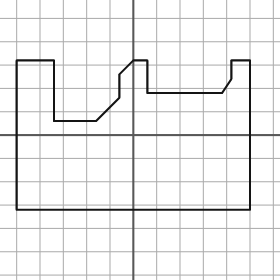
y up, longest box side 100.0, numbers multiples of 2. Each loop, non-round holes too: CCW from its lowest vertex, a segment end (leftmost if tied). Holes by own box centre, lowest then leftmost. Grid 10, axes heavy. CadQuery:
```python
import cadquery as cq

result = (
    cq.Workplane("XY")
    .moveTo(-50.0, -32.0)
    .lineTo(50.0, -32.0)
    .lineTo(50.0, 32.0)
    .lineTo(42.0, 32.0)
    .lineTo(42.0, 24.0)
    .lineTo(38.0, 18.0)
    .lineTo(6.0, 18.0)
    .lineTo(6.0, 32.0)
    .lineTo(0.0, 32.0)
    .lineTo(-6.0, 26.0)
    .lineTo(-6.0, 16.0)
    .lineTo(-16.0, 6.0)
    .lineTo(-34.0, 6.0)
    .lineTo(-34.0, 32.0)
    .lineTo(-50.0, 32.0)
    .close()
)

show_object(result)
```